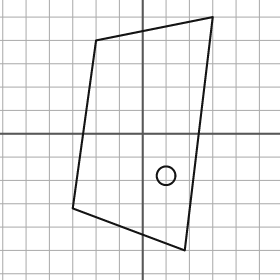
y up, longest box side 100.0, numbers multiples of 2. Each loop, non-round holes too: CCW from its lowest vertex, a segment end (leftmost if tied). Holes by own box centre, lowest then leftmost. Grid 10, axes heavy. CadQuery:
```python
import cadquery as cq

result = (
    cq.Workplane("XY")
    .moveTo(18.0, -50.0)
    .lineTo(30.0, 50.0)
    .lineTo(-20.0, 40.0)
    .lineTo(-30.0, -32.0)
    .close()
    .moveTo(10.0, -18.0)
    .circle(4.0)
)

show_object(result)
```